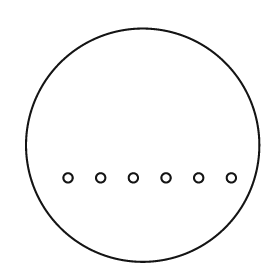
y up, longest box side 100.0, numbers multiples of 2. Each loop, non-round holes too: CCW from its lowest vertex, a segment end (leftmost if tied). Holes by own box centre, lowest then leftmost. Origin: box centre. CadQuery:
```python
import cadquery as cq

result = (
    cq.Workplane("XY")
    .moveTo(0.0, 0.0)
    .circle(50.0)
    .moveTo(-32.0, -14.0)
    .circle(2.0)
    .moveTo(-18.0, -14.0)
    .circle(2.0)
    .moveTo(-4.0, -14.0)
    .circle(2.0)
    .moveTo(10.0, -14.0)
    .circle(2.0)
    .moveTo(24.0, -14.0)
    .circle(2.0)
    .moveTo(38.0, -14.0)
    .circle(2.0)
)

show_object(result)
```